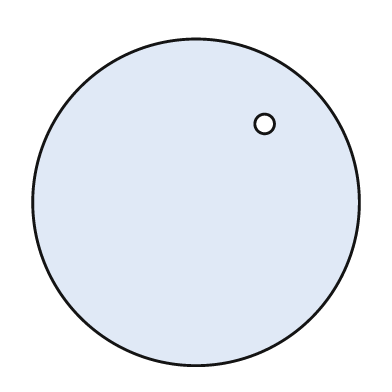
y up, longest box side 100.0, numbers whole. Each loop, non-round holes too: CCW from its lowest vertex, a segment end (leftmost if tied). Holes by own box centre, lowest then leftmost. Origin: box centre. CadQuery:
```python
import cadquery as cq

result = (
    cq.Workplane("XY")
    .moveTo(0.0, 0.0)
    .circle(50.0)
    .moveTo(21.0, 24.0)
    .circle(3.0)
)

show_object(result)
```